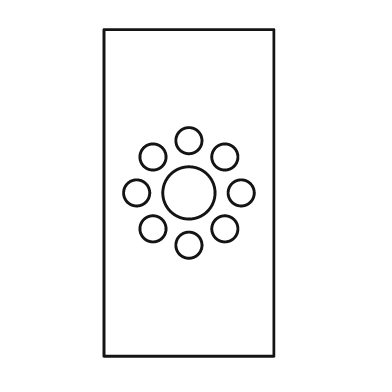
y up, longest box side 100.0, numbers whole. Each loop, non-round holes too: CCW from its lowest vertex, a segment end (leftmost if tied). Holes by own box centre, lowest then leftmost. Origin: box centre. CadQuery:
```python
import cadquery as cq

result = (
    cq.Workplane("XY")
    .moveTo(-26.0, -50.0)
    .lineTo(26.0, -50.0)
    .lineTo(26.0, 50.0)
    .lineTo(-26.0, 50.0)
    .close()
    .moveTo(0.0, -16.0)
    .circle(4.0)
    .moveTo(-11.0, -11.0)
    .circle(4.0)
    .moveTo(11.0, -11.0)
    .circle(4.0)
    .moveTo(-16.0, 0.0)
    .circle(4.0)
    .moveTo(0.0, 0.0)
    .circle(8.0)
    .moveTo(16.0, 0.0)
    .circle(4.0)
    .moveTo(-11.0, 11.0)
    .circle(4.0)
    .moveTo(11.0, 11.0)
    .circle(4.0)
    .moveTo(0.0, 16.0)
    .circle(4.0)
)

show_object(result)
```